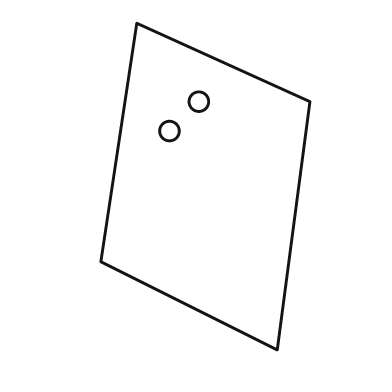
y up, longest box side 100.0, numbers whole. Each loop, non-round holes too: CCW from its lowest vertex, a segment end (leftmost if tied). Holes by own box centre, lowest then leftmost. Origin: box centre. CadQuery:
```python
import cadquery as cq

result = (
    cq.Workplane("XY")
    .moveTo(22.0, -50.0)
    .lineTo(32.0, 26.0)
    .lineTo(-21.0, 50.0)
    .lineTo(-32.0, -23.0)
    .close()
    .moveTo(-11.0, 17.0)
    .circle(3.0)
    .moveTo(-2.0, 26.0)
    .circle(3.0)
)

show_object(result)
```